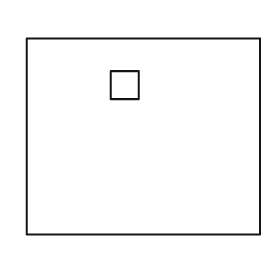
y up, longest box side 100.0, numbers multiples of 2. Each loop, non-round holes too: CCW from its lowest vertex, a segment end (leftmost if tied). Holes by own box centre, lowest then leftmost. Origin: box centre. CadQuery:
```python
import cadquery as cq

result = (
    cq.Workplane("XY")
    .moveTo(-50.0, -42.0)
    .lineTo(50.0, -42.0)
    .lineTo(50.0, 42.0)
    .lineTo(-50.0, 42.0)
    .close()
    .moveTo(-14.0, 16.0)
    .lineTo(-2.0, 16.0)
    .lineTo(-2.0, 28.0)
    .lineTo(-14.0, 28.0)
    .close()
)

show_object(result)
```